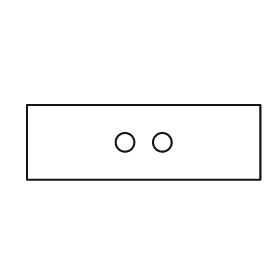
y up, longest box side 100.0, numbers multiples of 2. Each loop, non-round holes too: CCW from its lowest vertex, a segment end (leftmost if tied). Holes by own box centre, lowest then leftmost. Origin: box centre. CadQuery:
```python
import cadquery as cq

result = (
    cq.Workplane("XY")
    .moveTo(-50.0, -16.0)
    .lineTo(50.0, -16.0)
    .lineTo(50.0, 16.0)
    .lineTo(-50.0, 16.0)
    .close()
    .moveTo(-8.0, 0.0)
    .circle(4.0)
    .moveTo(8.0, 0.0)
    .circle(4.0)
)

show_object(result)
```